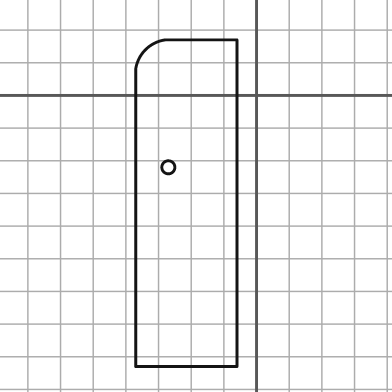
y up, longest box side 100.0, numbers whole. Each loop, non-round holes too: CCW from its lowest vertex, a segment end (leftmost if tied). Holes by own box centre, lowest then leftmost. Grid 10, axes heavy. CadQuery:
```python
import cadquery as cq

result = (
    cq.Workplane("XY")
    .moveTo(-37.0, -83.0)
    .lineTo(-6.0, -83.0)
    .lineTo(-6.0, 17.0)
    .lineTo(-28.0, 17.0)
    .threePointArc((-34.0, 14.0), (-37.0, 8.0))
    .close()
    .moveTo(-27.0, -22.0)
    .circle(2.0)
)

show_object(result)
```